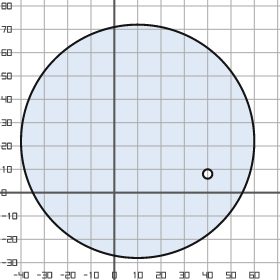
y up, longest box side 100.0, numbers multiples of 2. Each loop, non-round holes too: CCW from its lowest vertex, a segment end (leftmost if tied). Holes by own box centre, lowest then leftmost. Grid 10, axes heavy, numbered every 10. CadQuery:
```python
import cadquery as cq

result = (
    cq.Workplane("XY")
    .moveTo(10.0, 22.0)
    .circle(50.0)
    .moveTo(40.0, 8.0)
    .circle(2.0)
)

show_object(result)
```